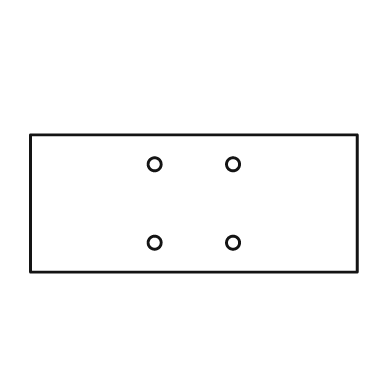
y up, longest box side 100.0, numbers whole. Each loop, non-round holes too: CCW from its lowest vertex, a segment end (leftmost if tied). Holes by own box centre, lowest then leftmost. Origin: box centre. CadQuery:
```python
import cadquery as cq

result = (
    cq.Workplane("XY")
    .moveTo(-50.0, -21.0)
    .lineTo(50.0, -21.0)
    .lineTo(50.0, 21.0)
    .lineTo(-50.0, 21.0)
    .close()
    .moveTo(-12.0, -12.0)
    .circle(2.0)
    .moveTo(12.0, -12.0)
    .circle(2.0)
    .moveTo(-12.0, 12.0)
    .circle(2.0)
    .moveTo(12.0, 12.0)
    .circle(2.0)
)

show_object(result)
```